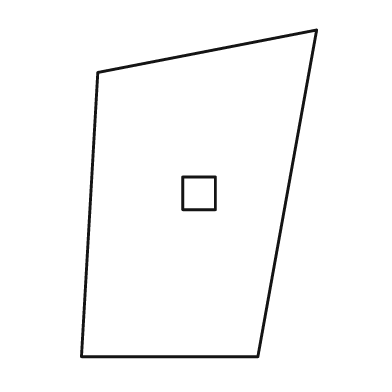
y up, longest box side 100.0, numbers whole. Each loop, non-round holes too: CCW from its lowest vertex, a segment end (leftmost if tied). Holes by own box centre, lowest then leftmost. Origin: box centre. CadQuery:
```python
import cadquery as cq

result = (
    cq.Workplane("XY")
    .moveTo(-36.0, -50.0)
    .lineTo(18.0, -50.0)
    .lineTo(36.0, 50.0)
    .lineTo(-31.0, 37.0)
    .close()
    .moveTo(-5.0, -5.0)
    .lineTo(5.0, -5.0)
    .lineTo(5.0, 5.0)
    .lineTo(-5.0, 5.0)
    .close()
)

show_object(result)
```